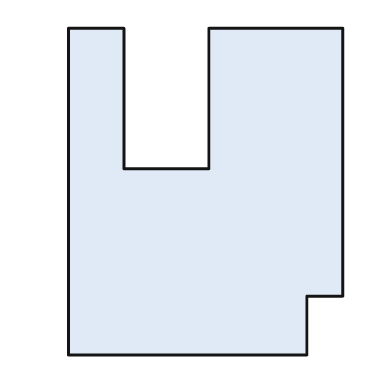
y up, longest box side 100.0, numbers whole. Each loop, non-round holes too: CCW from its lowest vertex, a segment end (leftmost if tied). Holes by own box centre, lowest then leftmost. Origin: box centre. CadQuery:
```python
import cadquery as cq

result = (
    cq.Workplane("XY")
    .moveTo(-42.0, -50.0)
    .lineTo(31.0, -50.0)
    .lineTo(31.0, -32.0)
    .lineTo(42.0, -32.0)
    .lineTo(42.0, 50.0)
    .lineTo(1.0, 50.0)
    .lineTo(1.0, 7.0)
    .lineTo(-25.0, 7.0)
    .lineTo(-25.0, 50.0)
    .lineTo(-42.0, 50.0)
    .close()
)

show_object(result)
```